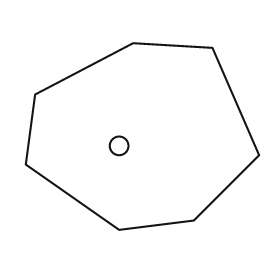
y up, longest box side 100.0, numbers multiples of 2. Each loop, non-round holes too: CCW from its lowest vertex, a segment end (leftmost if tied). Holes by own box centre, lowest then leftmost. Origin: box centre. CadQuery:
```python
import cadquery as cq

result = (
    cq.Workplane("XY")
    .moveTo(-10.0, -40.0)
    .lineTo(22.0, -36.0)
    .lineTo(50.0, -8.0)
    .lineTo(30.0, 38.0)
    .lineTo(-4.0, 40.0)
    .lineTo(-46.0, 18.0)
    .lineTo(-50.0, -12.0)
    .close()
    .moveTo(-10.0, -4.0)
    .circle(4.0)
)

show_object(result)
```